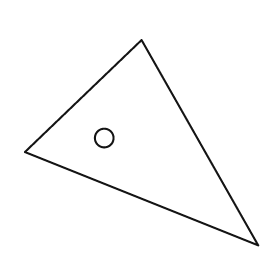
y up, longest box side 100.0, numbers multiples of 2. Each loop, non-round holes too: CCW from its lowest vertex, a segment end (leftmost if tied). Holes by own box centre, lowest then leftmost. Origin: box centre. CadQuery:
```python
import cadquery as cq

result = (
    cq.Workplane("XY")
    .moveTo(50.0, -44.0)
    .lineTo(0.0, 44.0)
    .lineTo(-50.0, -4.0)
    .close()
    .moveTo(-16.0, 2.0)
    .circle(4.0)
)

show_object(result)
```